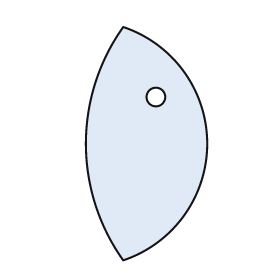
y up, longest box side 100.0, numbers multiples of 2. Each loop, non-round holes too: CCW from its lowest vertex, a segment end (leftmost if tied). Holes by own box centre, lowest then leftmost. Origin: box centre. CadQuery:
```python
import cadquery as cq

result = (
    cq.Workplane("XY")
    .moveTo(-10.0, -50.0)
    .threePointArc((26.0, 0.0), (-10.0, 50.0))
    .threePointArc((-26.0, 0.0), (-10.0, -50.0))
    .close()
    .moveTo(4.0, 20.0)
    .circle(4.0)
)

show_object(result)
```